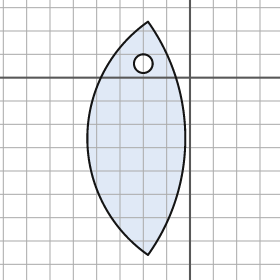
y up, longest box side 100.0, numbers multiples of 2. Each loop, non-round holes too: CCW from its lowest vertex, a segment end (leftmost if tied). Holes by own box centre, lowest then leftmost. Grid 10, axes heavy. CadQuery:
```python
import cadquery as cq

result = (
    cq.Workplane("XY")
    .moveTo(-18.0, -76.0)
    .threePointArc((-2.0, -26.0), (-18.0, 24.0))
    .threePointArc((-44.0, -26.0), (-18.0, -76.0))
    .close()
    .moveTo(-20.0, 6.0)
    .circle(4.0)
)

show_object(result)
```